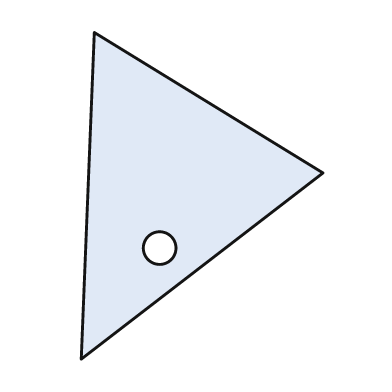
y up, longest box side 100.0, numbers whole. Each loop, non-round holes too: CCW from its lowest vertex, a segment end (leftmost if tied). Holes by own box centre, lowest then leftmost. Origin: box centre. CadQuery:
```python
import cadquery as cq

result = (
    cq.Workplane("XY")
    .moveTo(-37.0, -50.0)
    .lineTo(37.0, 7.0)
    .lineTo(-33.0, 50.0)
    .close()
    .moveTo(-13.0, -16.0)
    .circle(5.0)
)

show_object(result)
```